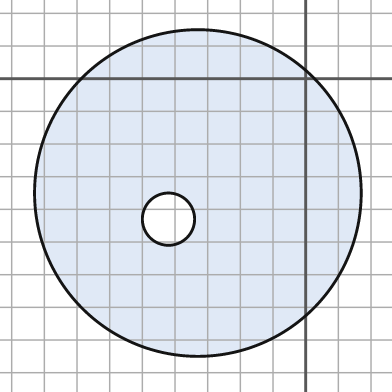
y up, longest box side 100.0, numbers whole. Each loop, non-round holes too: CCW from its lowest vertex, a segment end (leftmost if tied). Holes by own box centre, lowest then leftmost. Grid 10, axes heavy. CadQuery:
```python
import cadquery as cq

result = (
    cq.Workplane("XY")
    .moveTo(-33.0, -35.0)
    .circle(50.0)
    .moveTo(-42.0, -43.0)
    .circle(8.0)
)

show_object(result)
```